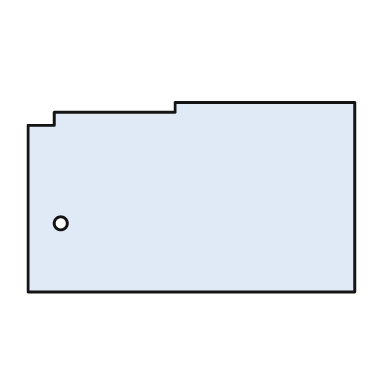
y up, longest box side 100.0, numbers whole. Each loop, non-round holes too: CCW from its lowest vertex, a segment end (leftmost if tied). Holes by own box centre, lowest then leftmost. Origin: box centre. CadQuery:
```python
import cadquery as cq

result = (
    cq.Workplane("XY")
    .moveTo(-50.0, -29.0)
    .lineTo(50.0, -29.0)
    .lineTo(50.0, 29.0)
    .lineTo(-5.0, 29.0)
    .lineTo(-5.0, 26.0)
    .lineTo(-42.0, 26.0)
    .lineTo(-42.0, 22.0)
    .lineTo(-50.0, 22.0)
    .close()
    .moveTo(-40.0, -8.0)
    .circle(2.0)
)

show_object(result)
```